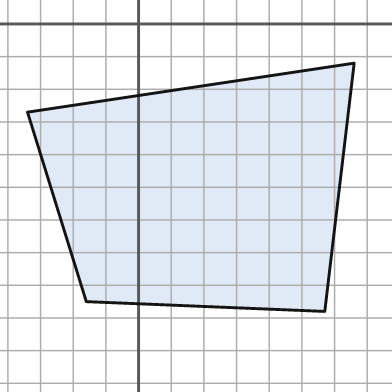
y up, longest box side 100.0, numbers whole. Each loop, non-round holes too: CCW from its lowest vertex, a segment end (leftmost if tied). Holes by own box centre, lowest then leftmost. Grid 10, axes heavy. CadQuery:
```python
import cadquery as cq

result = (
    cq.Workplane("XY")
    .moveTo(57.0, -88.0)
    .lineTo(66.0, -12.0)
    .lineTo(-34.0, -27.0)
    .lineTo(-16.0, -85.0)
    .close()
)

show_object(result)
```